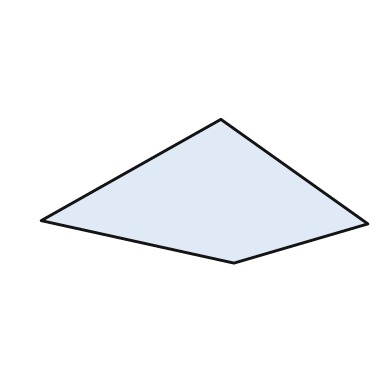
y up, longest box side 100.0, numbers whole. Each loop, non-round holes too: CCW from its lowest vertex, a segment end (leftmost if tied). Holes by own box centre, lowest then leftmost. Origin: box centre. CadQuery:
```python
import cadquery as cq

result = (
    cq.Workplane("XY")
    .moveTo(9.0, -22.0)
    .lineTo(50.0, -10.0)
    .lineTo(5.0, 22.0)
    .lineTo(-50.0, -9.0)
    .close()
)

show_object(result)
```